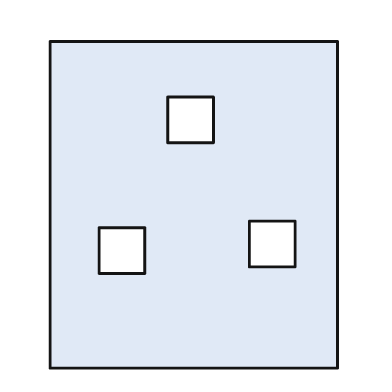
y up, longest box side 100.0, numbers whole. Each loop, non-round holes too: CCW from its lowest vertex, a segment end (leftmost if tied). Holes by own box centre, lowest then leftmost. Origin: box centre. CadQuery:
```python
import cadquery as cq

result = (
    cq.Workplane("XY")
    .moveTo(-44.0, -50.0)
    .lineTo(44.0, -50.0)
    .lineTo(44.0, 50.0)
    .lineTo(-44.0, 50.0)
    .close()
    .moveTo(-29.0, -21.0)
    .lineTo(-15.0, -21.0)
    .lineTo(-15.0, -7.0)
    .lineTo(-29.0, -7.0)
    .close()
    .moveTo(17.0, -19.0)
    .lineTo(31.0, -19.0)
    .lineTo(31.0, -5.0)
    .lineTo(17.0, -5.0)
    .close()
    .moveTo(-8.0, 19.0)
    .lineTo(6.0, 19.0)
    .lineTo(6.0, 33.0)
    .lineTo(-8.0, 33.0)
    .close()
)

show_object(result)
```